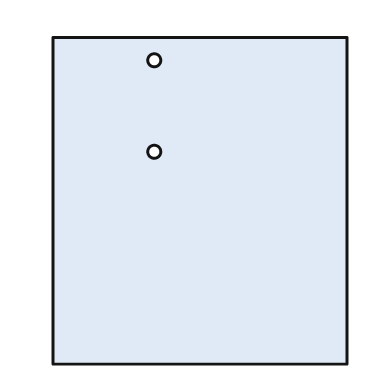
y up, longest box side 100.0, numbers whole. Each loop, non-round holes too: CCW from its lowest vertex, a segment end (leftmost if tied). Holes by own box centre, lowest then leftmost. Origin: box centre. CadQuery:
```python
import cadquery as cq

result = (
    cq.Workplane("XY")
    .moveTo(-45.0, -50.0)
    .lineTo(45.0, -50.0)
    .lineTo(45.0, 50.0)
    .lineTo(-45.0, 50.0)
    .close()
    .moveTo(-14.0, 15.0)
    .circle(2.0)
    .moveTo(-14.0, 43.0)
    .circle(2.0)
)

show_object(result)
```